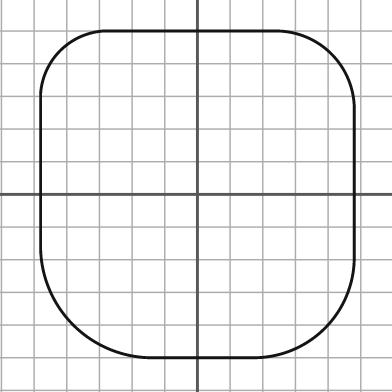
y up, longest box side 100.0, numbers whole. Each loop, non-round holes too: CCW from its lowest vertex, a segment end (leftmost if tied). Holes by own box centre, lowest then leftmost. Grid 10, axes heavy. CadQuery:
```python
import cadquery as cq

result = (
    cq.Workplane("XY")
    .moveTo(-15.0, -50.0)
    .lineTo(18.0, -50.0)
    .threePointArc((39.0, -41.0), (48.0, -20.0))
    .lineTo(48.0, 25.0)
    .threePointArc((41.0, 43.0), (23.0, 50.0))
    .lineTo(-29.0, 50.0)
    .threePointArc((-42.0, 44.0), (-48.0, 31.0))
    .lineTo(-48.0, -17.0)
    .threePointArc((-38.0, -40.0), (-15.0, -50.0))
    .close()
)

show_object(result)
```